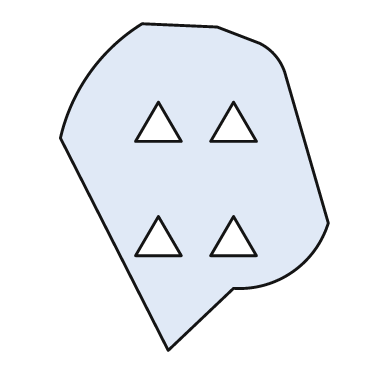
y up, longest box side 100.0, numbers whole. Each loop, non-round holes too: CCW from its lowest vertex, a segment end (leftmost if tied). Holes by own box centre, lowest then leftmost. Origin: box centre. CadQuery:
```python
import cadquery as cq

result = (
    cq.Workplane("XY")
    .moveTo(-8.0, -50.0)
    .lineTo(12.0, -31.0)
    .threePointArc((30.0, -26.0), (41.0, -11.0))
    .lineTo(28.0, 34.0)
    .threePointArc((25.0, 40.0), (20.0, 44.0))
    .lineTo(7.0, 49.0)
    .lineTo(-16.0, 50.0)
    .threePointArc((-32.0, 35.0), (-41.0, 15.0))
    .close()
    .moveTo(-18.0, -21.0)
    .lineTo(-4.0, -21.0)
    .lineTo(-11.0, -9.0)
    .close()
    .moveTo(5.0, -21.0)
    .lineTo(19.0, -21.0)
    .lineTo(12.0, -9.0)
    .close()
    .moveTo(-18.0, 14.0)
    .lineTo(-4.0, 14.0)
    .lineTo(-11.0, 26.0)
    .close()
    .moveTo(5.0, 14.0)
    .lineTo(19.0, 14.0)
    .lineTo(12.0, 26.0)
    .close()
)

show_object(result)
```